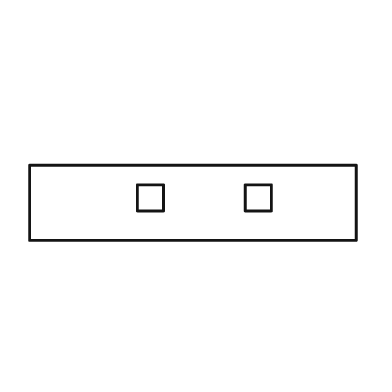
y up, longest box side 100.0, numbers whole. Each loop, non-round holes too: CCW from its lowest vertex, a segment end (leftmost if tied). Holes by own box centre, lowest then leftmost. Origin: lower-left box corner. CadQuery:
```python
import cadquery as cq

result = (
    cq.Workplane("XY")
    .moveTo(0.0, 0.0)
    .lineTo(100.0, 0.0)
    .lineTo(100.0, 23.0)
    .lineTo(0.0, 23.0)
    .close()
    .moveTo(33.0, 9.0)
    .lineTo(41.0, 9.0)
    .lineTo(41.0, 17.0)
    .lineTo(33.0, 17.0)
    .close()
    .moveTo(66.0, 9.0)
    .lineTo(74.0, 9.0)
    .lineTo(74.0, 17.0)
    .lineTo(66.0, 17.0)
    .close()
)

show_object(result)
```